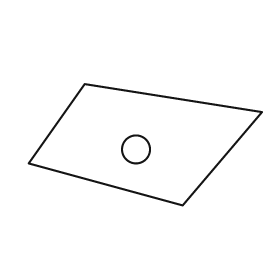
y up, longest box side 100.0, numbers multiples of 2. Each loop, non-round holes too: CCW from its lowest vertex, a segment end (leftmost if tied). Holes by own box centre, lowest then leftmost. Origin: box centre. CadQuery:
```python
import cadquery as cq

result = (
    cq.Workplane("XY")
    .moveTo(16.0, -26.0)
    .lineTo(50.0, 14.0)
    .lineTo(-26.0, 26.0)
    .lineTo(-50.0, -8.0)
    .close()
    .moveTo(-4.0, -2.0)
    .circle(6.0)
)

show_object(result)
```